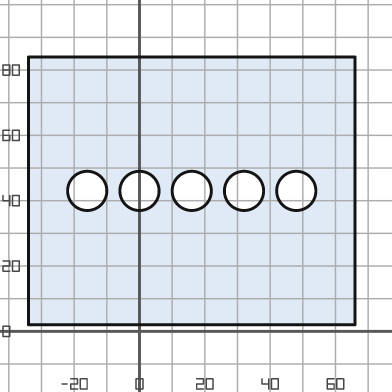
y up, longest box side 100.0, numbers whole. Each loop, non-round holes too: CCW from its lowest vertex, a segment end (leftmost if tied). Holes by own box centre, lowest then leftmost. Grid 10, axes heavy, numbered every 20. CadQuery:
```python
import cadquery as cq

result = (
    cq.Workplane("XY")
    .moveTo(-34.0, 2.0)
    .lineTo(66.0, 2.0)
    .lineTo(66.0, 84.0)
    .lineTo(-34.0, 84.0)
    .close()
    .moveTo(-16.0, 43.0)
    .circle(6.0)
    .moveTo(0.0, 43.0)
    .circle(6.0)
    .moveTo(16.0, 43.0)
    .circle(6.0)
    .moveTo(32.0, 43.0)
    .circle(6.0)
    .moveTo(48.0, 43.0)
    .circle(6.0)
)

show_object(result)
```